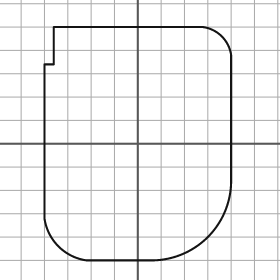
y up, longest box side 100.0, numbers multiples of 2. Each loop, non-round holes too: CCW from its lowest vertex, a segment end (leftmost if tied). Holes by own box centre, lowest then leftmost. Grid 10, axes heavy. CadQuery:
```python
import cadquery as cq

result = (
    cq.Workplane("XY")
    .moveTo(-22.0, -50.0)
    .lineTo(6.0, -50.0)
    .threePointArc((30.0, -40.0), (40.0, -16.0))
    .lineTo(40.0, 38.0)
    .threePointArc((36.0, 46.0), (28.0, 50.0))
    .lineTo(-36.0, 50.0)
    .lineTo(-36.0, 34.0)
    .lineTo(-40.0, 34.0)
    .lineTo(-40.0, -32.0)
    .threePointArc((-34.0, -44.0), (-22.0, -50.0))
    .close()
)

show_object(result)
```